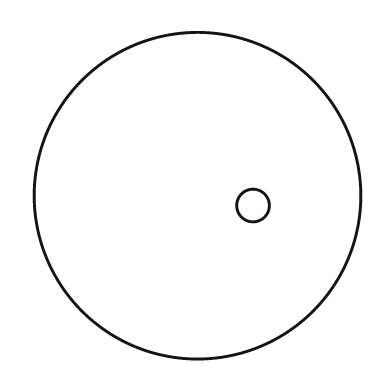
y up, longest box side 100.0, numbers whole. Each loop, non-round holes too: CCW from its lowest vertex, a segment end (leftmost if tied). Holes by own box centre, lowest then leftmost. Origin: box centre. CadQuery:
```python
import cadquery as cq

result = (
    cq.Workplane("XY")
    .moveTo(0.0, 0.0)
    .circle(50.0)
    .moveTo(17.0, -3.0)
    .circle(5.0)
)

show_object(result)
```